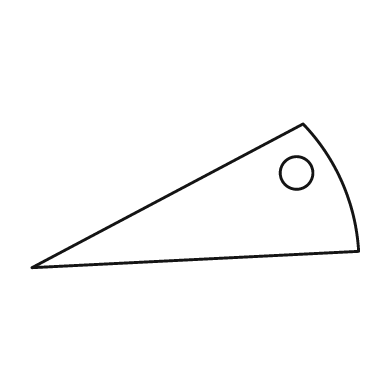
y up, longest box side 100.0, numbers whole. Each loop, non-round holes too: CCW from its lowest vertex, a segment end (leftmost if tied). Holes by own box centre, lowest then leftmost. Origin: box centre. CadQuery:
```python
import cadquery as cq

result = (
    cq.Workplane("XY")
    .moveTo(-50.0, -22.0)
    .lineTo(50.0, -17.0)
    .threePointArc((45.0, 4.0), (33.0, 22.0))
    .close()
    .moveTo(31.0, 7.0)
    .circle(5.0)
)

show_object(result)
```